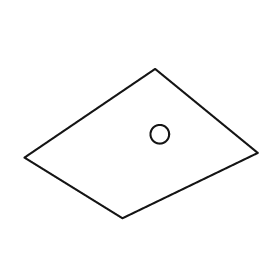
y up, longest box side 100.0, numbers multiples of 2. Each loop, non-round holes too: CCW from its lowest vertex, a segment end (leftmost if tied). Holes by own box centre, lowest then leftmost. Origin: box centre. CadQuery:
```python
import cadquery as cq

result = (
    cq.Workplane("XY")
    .moveTo(-8.0, -32.0)
    .lineTo(50.0, -4.0)
    .lineTo(6.0, 32.0)
    .lineTo(-50.0, -6.0)
    .close()
    .moveTo(8.0, 4.0)
    .circle(4.0)
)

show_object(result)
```